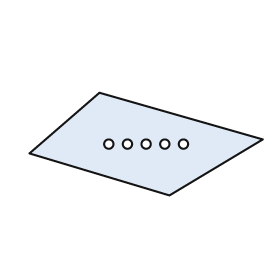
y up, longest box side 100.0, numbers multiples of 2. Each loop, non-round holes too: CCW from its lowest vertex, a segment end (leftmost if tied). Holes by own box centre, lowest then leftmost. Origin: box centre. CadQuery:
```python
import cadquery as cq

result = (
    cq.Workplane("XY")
    .moveTo(10.0, -22.0)
    .lineTo(50.0, 2.0)
    .lineTo(-20.0, 22.0)
    .lineTo(-50.0, -4.0)
    .close()
    .moveTo(-16.0, 0.0)
    .circle(2.0)
    .moveTo(-8.0, 0.0)
    .circle(2.0)
    .moveTo(0.0, 0.0)
    .circle(2.0)
    .moveTo(8.0, 0.0)
    .circle(2.0)
    .moveTo(16.0, 0.0)
    .circle(2.0)
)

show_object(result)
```